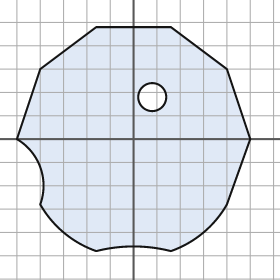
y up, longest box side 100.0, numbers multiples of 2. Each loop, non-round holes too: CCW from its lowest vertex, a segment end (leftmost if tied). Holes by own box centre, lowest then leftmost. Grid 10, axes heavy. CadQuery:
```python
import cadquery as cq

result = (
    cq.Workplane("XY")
    .moveTo(-16.0, -48.0)
    .threePointArc((0.0, -46.0), (16.0, -48.0))
    .threePointArc((30.0, -40.0), (40.0, -28.0))
    .lineTo(50.0, 0.0)
    .lineTo(40.0, 30.0)
    .lineTo(16.0, 48.0)
    .lineTo(-16.0, 48.0)
    .lineTo(-40.0, 30.0)
    .lineTo(-50.0, 0.0)
    .threePointArc((-40.0, -12.0), (-40.0, -28.0))
    .threePointArc((-30.0, -40.0), (-16.0, -48.0))
    .close()
    .moveTo(8.0, 18.0)
    .circle(6.0)
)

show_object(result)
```